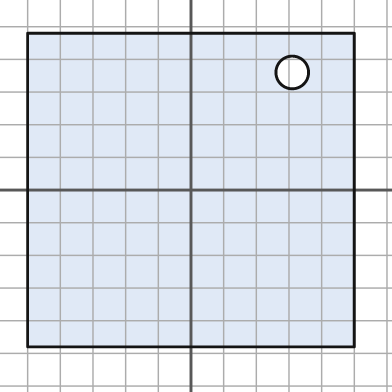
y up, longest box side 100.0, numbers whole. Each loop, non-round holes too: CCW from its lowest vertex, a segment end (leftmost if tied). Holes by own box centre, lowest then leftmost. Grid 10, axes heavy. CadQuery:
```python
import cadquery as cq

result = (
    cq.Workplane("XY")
    .moveTo(-50.0, -48.0)
    .lineTo(50.0, -48.0)
    .lineTo(50.0, 48.0)
    .lineTo(-50.0, 48.0)
    .close()
    .moveTo(31.0, 36.0)
    .circle(5.0)
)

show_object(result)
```